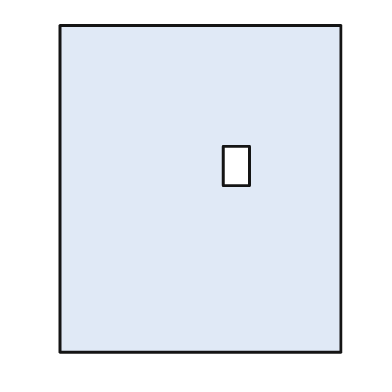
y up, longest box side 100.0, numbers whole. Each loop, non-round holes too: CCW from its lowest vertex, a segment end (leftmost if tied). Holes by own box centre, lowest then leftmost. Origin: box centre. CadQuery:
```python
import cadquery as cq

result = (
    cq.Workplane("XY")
    .moveTo(-43.0, -50.0)
    .lineTo(43.0, -50.0)
    .lineTo(43.0, 50.0)
    .lineTo(-43.0, 50.0)
    .close()
    .moveTo(7.0, 1.0)
    .lineTo(15.0, 1.0)
    .lineTo(15.0, 13.0)
    .lineTo(7.0, 13.0)
    .close()
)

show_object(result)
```